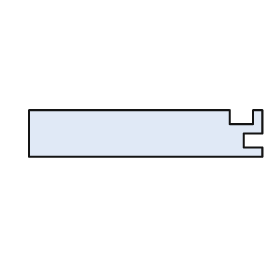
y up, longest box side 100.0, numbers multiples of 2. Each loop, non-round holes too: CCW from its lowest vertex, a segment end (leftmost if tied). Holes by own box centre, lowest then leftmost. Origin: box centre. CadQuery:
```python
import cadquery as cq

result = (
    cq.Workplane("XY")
    .moveTo(-50.0, -10.0)
    .lineTo(50.0, -10.0)
    .lineTo(50.0, -6.0)
    .lineTo(42.0, -6.0)
    .lineTo(42.0, 0.0)
    .lineTo(50.0, 0.0)
    .lineTo(50.0, 10.0)
    .lineTo(46.0, 10.0)
    .lineTo(46.0, 4.0)
    .lineTo(36.0, 4.0)
    .lineTo(36.0, 10.0)
    .lineTo(-50.0, 10.0)
    .close()
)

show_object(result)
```